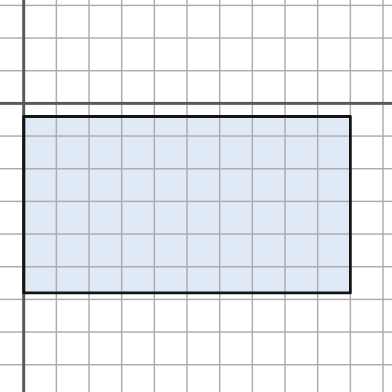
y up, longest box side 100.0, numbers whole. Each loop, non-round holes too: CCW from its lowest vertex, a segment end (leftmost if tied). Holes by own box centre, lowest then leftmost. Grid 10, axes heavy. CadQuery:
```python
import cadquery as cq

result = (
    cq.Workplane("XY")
    .moveTo(0.0, -58.0)
    .lineTo(100.0, -58.0)
    .lineTo(100.0, -4.0)
    .lineTo(0.0, -4.0)
    .close()
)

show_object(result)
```